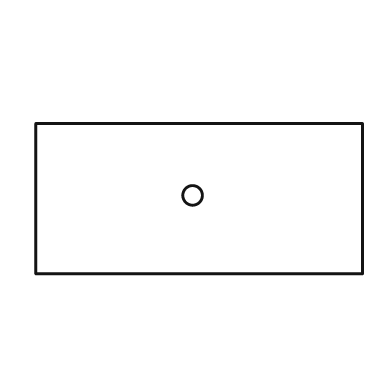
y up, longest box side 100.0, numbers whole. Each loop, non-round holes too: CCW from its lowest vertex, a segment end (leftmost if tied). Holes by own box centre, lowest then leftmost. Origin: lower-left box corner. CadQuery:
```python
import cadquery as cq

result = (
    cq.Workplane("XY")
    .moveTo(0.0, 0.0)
    .lineTo(100.0, 0.0)
    .lineTo(100.0, 46.0)
    .lineTo(0.0, 46.0)
    .close()
    .moveTo(48.0, 24.0)
    .circle(3.0)
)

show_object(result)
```